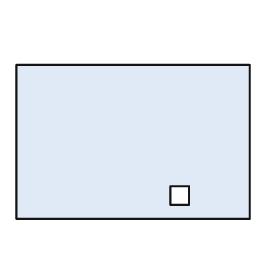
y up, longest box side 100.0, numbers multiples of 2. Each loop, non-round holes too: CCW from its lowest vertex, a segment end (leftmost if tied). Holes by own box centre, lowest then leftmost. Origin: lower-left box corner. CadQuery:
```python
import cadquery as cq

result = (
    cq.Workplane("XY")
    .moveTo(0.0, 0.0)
    .lineTo(100.0, 0.0)
    .lineTo(100.0, 66.0)
    .lineTo(0.0, 66.0)
    .close()
    .moveTo(66.0, 6.0)
    .lineTo(74.0, 6.0)
    .lineTo(74.0, 14.0)
    .lineTo(66.0, 14.0)
    .close()
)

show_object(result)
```